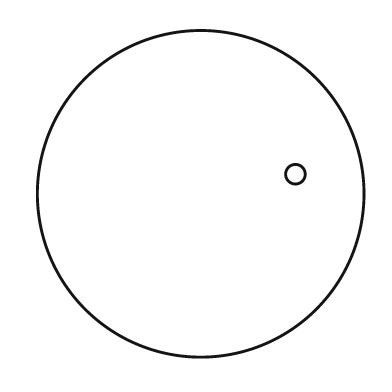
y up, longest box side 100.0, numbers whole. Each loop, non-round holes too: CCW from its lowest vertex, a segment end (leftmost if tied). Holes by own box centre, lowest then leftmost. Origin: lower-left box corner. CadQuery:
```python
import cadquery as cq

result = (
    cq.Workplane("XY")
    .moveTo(50.0, 50.0)
    .circle(50.0)
    .moveTo(79.0, 56.0)
    .circle(3.0)
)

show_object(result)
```